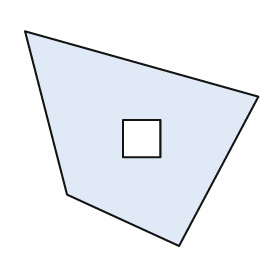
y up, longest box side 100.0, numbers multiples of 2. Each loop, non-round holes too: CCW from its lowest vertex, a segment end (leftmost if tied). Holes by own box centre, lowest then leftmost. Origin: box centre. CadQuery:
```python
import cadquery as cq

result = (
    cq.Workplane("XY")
    .moveTo(16.0, -46.0)
    .lineTo(50.0, 18.0)
    .lineTo(-50.0, 46.0)
    .lineTo(-32.0, -24.0)
    .close()
    .moveTo(-8.0, -8.0)
    .lineTo(8.0, -8.0)
    .lineTo(8.0, 8.0)
    .lineTo(-8.0, 8.0)
    .close()
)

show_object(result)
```